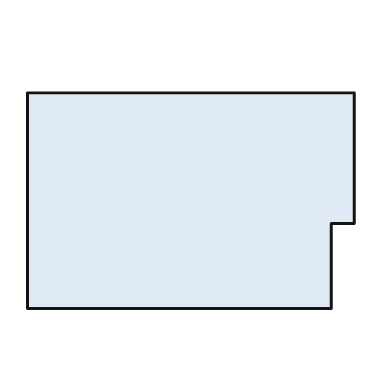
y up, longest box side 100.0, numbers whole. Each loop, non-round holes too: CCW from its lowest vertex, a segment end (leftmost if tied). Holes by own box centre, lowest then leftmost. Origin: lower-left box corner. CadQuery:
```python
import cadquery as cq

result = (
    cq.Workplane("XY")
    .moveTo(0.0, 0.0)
    .lineTo(93.0, 0.0)
    .lineTo(93.0, 26.0)
    .lineTo(100.0, 26.0)
    .lineTo(100.0, 66.0)
    .lineTo(0.0, 66.0)
    .close()
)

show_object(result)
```